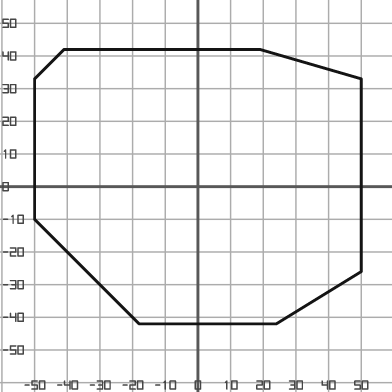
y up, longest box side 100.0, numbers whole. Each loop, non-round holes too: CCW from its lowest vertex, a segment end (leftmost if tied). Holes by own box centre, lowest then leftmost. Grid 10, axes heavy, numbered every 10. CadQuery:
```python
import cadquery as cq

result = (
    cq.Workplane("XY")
    .moveTo(-18.0, -42.0)
    .lineTo(24.0, -42.0)
    .lineTo(50.0, -26.0)
    .lineTo(50.0, 33.0)
    .lineTo(19.0, 42.0)
    .lineTo(-41.0, 42.0)
    .lineTo(-50.0, 33.0)
    .lineTo(-50.0, -10.0)
    .close()
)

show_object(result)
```